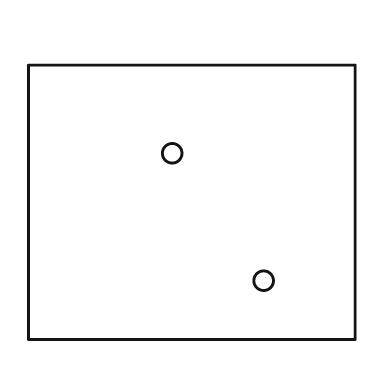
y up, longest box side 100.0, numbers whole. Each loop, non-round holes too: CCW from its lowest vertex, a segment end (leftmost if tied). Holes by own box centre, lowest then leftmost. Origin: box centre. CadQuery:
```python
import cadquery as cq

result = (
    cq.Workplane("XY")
    .moveTo(-50.0, -42.0)
    .lineTo(50.0, -42.0)
    .lineTo(50.0, 42.0)
    .lineTo(-50.0, 42.0)
    .close()
    .moveTo(22.0, -24.0)
    .circle(3.0)
    .moveTo(-6.0, 15.0)
    .circle(3.0)
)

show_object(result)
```